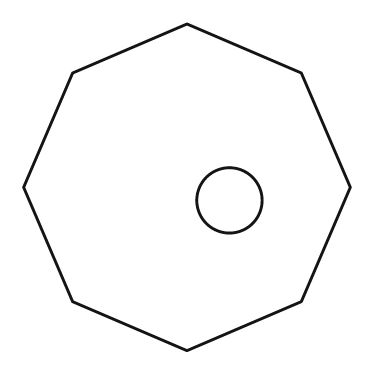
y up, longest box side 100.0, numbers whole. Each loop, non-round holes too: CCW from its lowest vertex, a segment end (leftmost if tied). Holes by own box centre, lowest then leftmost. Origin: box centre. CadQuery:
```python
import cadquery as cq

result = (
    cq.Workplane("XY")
    .moveTo(0.0, -50.0)
    .lineTo(35.0, -35.0)
    .lineTo(50.0, 0.0)
    .lineTo(35.0, 35.0)
    .lineTo(0.0, 50.0)
    .lineTo(-35.0, 35.0)
    .lineTo(-50.0, 0.0)
    .lineTo(-35.0, -35.0)
    .close()
    .moveTo(13.0, -4.0)
    .circle(10.0)
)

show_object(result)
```